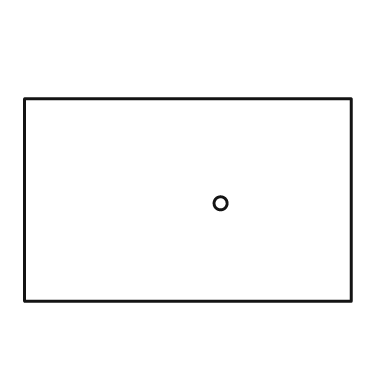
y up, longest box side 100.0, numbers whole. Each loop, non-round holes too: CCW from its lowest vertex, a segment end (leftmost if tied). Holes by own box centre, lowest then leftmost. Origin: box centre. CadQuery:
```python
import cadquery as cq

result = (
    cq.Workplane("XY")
    .moveTo(-50.0, -31.0)
    .lineTo(50.0, -31.0)
    .lineTo(50.0, 31.0)
    .lineTo(-50.0, 31.0)
    .close()
    .moveTo(10.0, -1.0)
    .circle(2.0)
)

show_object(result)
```